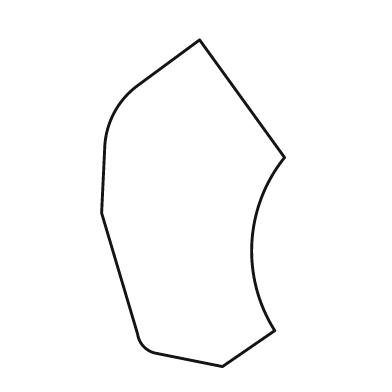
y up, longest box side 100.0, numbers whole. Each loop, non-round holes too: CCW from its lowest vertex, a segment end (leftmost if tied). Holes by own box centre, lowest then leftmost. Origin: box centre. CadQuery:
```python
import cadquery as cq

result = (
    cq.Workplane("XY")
    .moveTo(9.0, -50.0)
    .lineTo(25.0, -39.0)
    .threePointArc((18.0, -12.0), (28.0, 14.0))
    .lineTo(2.0, 50.0)
    .lineTo(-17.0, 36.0)
    .threePointArc((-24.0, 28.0), (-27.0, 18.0))
    .lineTo(-28.0, -3.0)
    .lineTo(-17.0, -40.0)
    .threePointArc((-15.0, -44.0), (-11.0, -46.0))
    .close()
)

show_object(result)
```